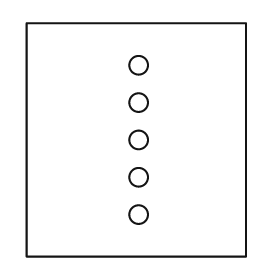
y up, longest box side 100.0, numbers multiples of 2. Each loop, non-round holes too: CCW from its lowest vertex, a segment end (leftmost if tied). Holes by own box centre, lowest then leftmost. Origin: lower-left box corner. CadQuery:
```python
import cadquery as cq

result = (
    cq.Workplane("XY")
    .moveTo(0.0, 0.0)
    .lineTo(94.0, 0.0)
    .lineTo(94.0, 100.0)
    .lineTo(0.0, 100.0)
    .close()
    .moveTo(48.0, 18.0)
    .circle(4.0)
    .moveTo(48.0, 34.0)
    .circle(4.0)
    .moveTo(48.0, 50.0)
    .circle(4.0)
    .moveTo(48.0, 66.0)
    .circle(4.0)
    .moveTo(48.0, 82.0)
    .circle(4.0)
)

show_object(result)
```